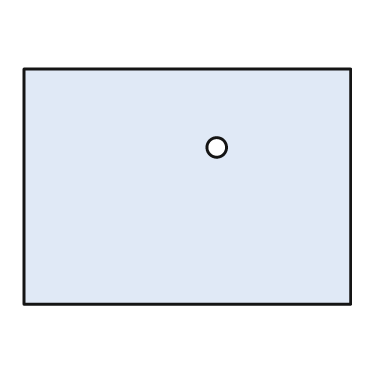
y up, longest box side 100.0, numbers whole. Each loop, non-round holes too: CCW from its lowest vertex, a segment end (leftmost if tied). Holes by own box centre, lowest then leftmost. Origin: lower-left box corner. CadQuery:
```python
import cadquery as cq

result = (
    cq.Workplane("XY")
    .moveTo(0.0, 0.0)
    .lineTo(100.0, 0.0)
    .lineTo(100.0, 72.0)
    .lineTo(0.0, 72.0)
    .close()
    .moveTo(59.0, 48.0)
    .circle(3.0)
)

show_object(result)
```